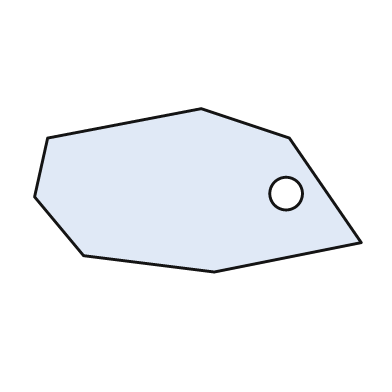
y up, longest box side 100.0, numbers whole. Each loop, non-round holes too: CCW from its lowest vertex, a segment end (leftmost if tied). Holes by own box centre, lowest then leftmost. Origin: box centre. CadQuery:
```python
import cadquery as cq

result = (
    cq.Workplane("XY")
    .moveTo(5.0, -25.0)
    .lineTo(50.0, -16.0)
    .lineTo(28.0, 16.0)
    .lineTo(1.0, 25.0)
    .lineTo(-46.0, 16.0)
    .lineTo(-50.0, -2.0)
    .lineTo(-35.0, -20.0)
    .close()
    .moveTo(27.0, -1.0)
    .circle(5.0)
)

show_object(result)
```